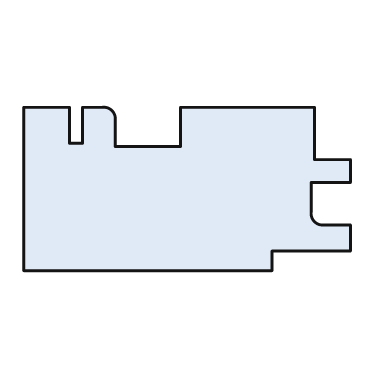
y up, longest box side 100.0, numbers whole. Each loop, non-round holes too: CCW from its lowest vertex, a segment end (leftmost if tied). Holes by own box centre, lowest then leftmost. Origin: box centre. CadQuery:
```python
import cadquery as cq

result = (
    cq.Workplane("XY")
    .moveTo(-50.0, -25.0)
    .lineTo(26.0, -25.0)
    .lineTo(26.0, -19.0)
    .lineTo(50.0, -19.0)
    .lineTo(50.0, -11.0)
    .lineTo(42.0, -11.0)
    .threePointArc((39.0, -10.0), (38.0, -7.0))
    .lineTo(38.0, 2.0)
    .lineTo(50.0, 2.0)
    .lineTo(50.0, 9.0)
    .lineTo(39.0, 9.0)
    .lineTo(39.0, 25.0)
    .lineTo(-2.0, 25.0)
    .lineTo(-2.0, 13.0)
    .lineTo(-22.0, 13.0)
    .lineTo(-22.0, 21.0)
    .threePointArc((-23.0, 24.0), (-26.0, 25.0))
    .lineTo(-32.0, 25.0)
    .lineTo(-32.0, 14.0)
    .lineTo(-36.0, 14.0)
    .lineTo(-36.0, 25.0)
    .lineTo(-50.0, 25.0)
    .close()
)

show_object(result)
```